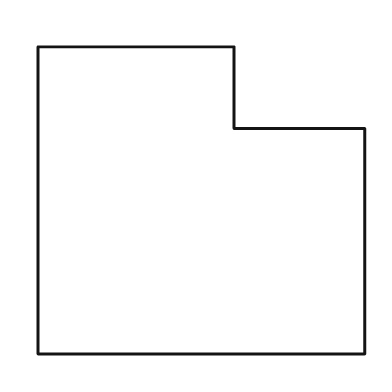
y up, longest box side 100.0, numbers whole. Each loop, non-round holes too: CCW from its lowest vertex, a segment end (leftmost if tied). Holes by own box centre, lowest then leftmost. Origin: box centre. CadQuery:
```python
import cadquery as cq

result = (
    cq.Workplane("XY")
    .moveTo(-50.0, -47.0)
    .lineTo(50.0, -47.0)
    .lineTo(50.0, 22.0)
    .lineTo(10.0, 22.0)
    .lineTo(10.0, 47.0)
    .lineTo(-50.0, 47.0)
    .close()
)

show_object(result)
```